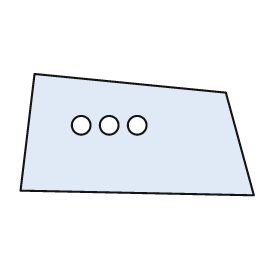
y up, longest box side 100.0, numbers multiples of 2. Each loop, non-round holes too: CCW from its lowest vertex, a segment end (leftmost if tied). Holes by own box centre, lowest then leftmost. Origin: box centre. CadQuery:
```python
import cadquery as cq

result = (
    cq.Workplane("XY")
    .moveTo(50.0, -26.0)
    .lineTo(38.0, 18.0)
    .lineTo(-44.0, 26.0)
    .lineTo(-50.0, -24.0)
    .close()
    .moveTo(-24.0, 4.0)
    .circle(4.0)
    .moveTo(-12.0, 4.0)
    .circle(4.0)
    .moveTo(0.0, 4.0)
    .circle(4.0)
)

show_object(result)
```